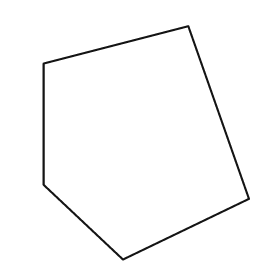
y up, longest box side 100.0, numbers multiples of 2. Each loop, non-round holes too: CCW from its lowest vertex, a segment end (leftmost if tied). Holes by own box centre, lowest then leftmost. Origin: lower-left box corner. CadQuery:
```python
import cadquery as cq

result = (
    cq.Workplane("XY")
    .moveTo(34.0, 0.0)
    .lineTo(88.0, 26.0)
    .lineTo(62.0, 100.0)
    .lineTo(0.0, 84.0)
    .lineTo(0.0, 32.0)
    .close()
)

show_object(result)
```